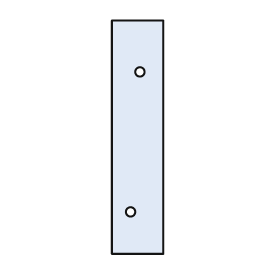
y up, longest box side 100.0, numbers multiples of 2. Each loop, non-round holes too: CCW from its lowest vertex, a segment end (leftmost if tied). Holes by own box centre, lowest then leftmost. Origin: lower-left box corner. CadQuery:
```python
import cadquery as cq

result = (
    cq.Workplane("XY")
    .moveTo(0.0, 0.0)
    .lineTo(22.0, 0.0)
    .lineTo(22.0, 100.0)
    .lineTo(0.0, 100.0)
    .close()
    .moveTo(8.0, 18.0)
    .circle(2.0)
    .moveTo(12.0, 78.0)
    .circle(2.0)
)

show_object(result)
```